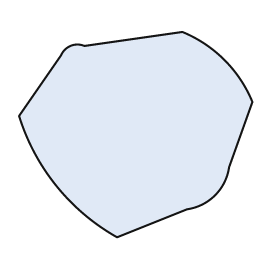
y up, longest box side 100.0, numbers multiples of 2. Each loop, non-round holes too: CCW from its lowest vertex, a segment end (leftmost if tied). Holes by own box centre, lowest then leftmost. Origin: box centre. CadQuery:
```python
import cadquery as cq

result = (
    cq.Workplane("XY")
    .moveTo(-8.0, -44.0)
    .lineTo(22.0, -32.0)
    .threePointArc((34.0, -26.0), (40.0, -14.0))
    .lineTo(50.0, 14.0)
    .threePointArc((38.0, 32.0), (20.0, 44.0))
    .lineTo(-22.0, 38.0)
    .threePointArc((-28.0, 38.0), (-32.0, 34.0))
    .lineTo(-50.0, 8.0)
    .threePointArc((-34.0, -22.0), (-8.0, -44.0))
    .close()
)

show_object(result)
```